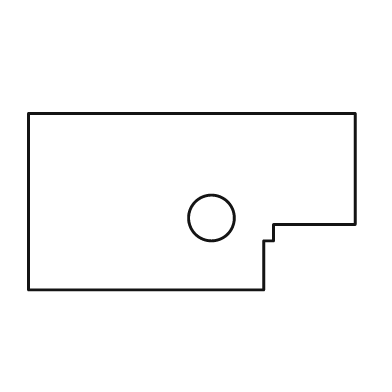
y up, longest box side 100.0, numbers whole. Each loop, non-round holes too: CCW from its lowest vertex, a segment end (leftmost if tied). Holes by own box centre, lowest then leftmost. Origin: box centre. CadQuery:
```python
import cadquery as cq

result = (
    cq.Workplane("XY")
    .moveTo(-50.0, -27.0)
    .lineTo(22.0, -27.0)
    .lineTo(22.0, -12.0)
    .lineTo(25.0, -12.0)
    .lineTo(25.0, -7.0)
    .lineTo(50.0, -7.0)
    .lineTo(50.0, 27.0)
    .lineTo(-50.0, 27.0)
    .close()
    .moveTo(6.0, -5.0)
    .circle(7.0)
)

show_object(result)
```